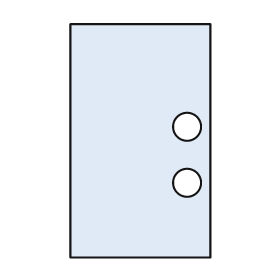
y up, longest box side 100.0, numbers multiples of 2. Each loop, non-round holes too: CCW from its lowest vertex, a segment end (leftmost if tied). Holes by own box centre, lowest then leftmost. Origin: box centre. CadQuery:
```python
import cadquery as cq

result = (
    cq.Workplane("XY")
    .moveTo(-30.0, -50.0)
    .lineTo(30.0, -50.0)
    .lineTo(30.0, 50.0)
    .lineTo(-30.0, 50.0)
    .close()
    .moveTo(20.0, -18.0)
    .circle(6.0)
    .moveTo(20.0, 6.0)
    .circle(6.0)
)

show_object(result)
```